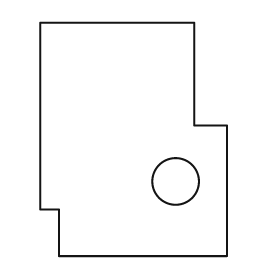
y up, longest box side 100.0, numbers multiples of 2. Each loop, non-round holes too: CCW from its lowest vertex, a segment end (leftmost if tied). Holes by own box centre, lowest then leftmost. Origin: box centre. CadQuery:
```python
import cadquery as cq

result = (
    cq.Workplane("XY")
    .moveTo(-32.0, -50.0)
    .lineTo(40.0, -50.0)
    .lineTo(40.0, 6.0)
    .lineTo(26.0, 6.0)
    .lineTo(26.0, 50.0)
    .lineTo(-40.0, 50.0)
    .lineTo(-40.0, -30.0)
    .lineTo(-32.0, -30.0)
    .close()
    .moveTo(18.0, -18.0)
    .circle(10.0)
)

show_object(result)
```